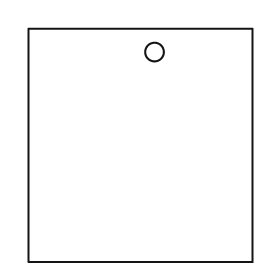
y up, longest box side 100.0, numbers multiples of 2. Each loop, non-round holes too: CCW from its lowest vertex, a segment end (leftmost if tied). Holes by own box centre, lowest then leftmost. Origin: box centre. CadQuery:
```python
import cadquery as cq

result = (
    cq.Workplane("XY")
    .moveTo(-48.0, -50.0)
    .lineTo(48.0, -50.0)
    .lineTo(48.0, 50.0)
    .lineTo(-48.0, 50.0)
    .close()
    .moveTo(6.0, 40.0)
    .circle(4.0)
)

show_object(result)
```